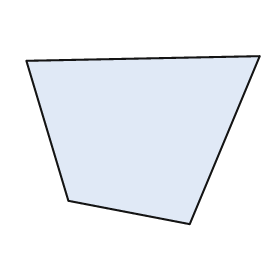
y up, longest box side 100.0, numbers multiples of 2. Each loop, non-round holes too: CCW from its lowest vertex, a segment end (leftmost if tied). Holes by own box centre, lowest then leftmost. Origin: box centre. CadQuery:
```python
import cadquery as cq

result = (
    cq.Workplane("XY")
    .moveTo(20.0, -36.0)
    .lineTo(50.0, 36.0)
    .lineTo(-50.0, 34.0)
    .lineTo(-32.0, -26.0)
    .close()
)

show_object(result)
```